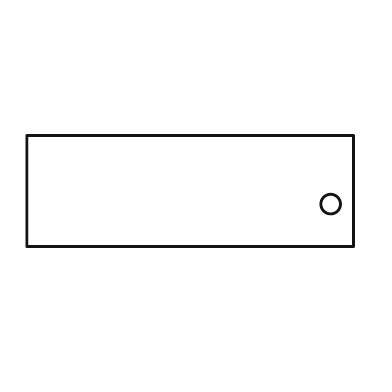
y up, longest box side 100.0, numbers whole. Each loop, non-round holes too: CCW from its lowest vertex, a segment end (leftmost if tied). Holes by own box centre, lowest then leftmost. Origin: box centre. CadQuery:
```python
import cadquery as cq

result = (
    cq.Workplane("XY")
    .moveTo(-50.0, -17.0)
    .lineTo(50.0, -17.0)
    .lineTo(50.0, 17.0)
    .lineTo(-50.0, 17.0)
    .close()
    .moveTo(43.0, -4.0)
    .circle(3.0)
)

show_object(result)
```